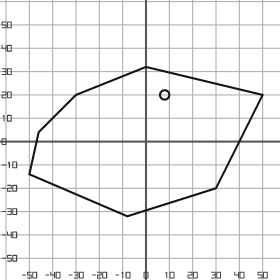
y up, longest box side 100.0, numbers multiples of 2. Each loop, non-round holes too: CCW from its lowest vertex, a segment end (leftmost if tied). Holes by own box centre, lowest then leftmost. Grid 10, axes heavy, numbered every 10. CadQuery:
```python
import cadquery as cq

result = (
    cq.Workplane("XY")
    .moveTo(-8.0, -32.0)
    .lineTo(30.0, -20.0)
    .lineTo(50.0, 20.0)
    .lineTo(0.0, 32.0)
    .lineTo(-30.0, 20.0)
    .lineTo(-46.0, 4.0)
    .lineTo(-50.0, -14.0)
    .close()
    .moveTo(8.0, 20.0)
    .circle(2.0)
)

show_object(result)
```